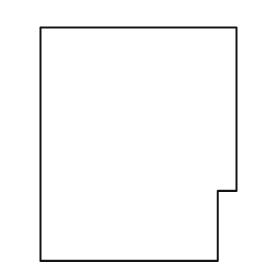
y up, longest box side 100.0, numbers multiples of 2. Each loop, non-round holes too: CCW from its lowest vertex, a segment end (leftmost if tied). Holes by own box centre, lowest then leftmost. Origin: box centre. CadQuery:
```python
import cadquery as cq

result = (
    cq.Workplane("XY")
    .moveTo(-42.0, -50.0)
    .lineTo(34.0, -50.0)
    .lineTo(34.0, -20.0)
    .lineTo(42.0, -20.0)
    .lineTo(42.0, 50.0)
    .lineTo(-42.0, 50.0)
    .close()
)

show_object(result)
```